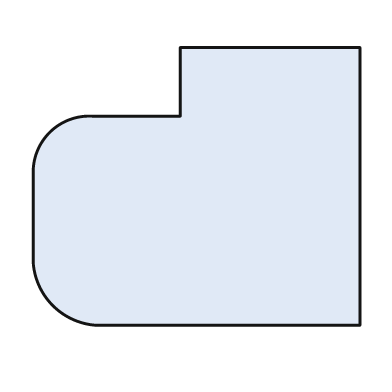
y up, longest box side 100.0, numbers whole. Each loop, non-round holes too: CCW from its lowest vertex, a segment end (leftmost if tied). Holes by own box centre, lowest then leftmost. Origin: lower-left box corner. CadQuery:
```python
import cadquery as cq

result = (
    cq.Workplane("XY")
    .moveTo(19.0, 0.0)
    .lineTo(100.0, 0.0)
    .lineTo(100.0, 85.0)
    .lineTo(45.0, 85.0)
    .lineTo(45.0, 64.0)
    .lineTo(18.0, 64.0)
    .threePointArc((5.0, 59.0), (0.0, 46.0))
    .lineTo(0.0, 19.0)
    .threePointArc((6.0, 6.0), (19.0, 0.0))
    .close()
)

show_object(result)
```